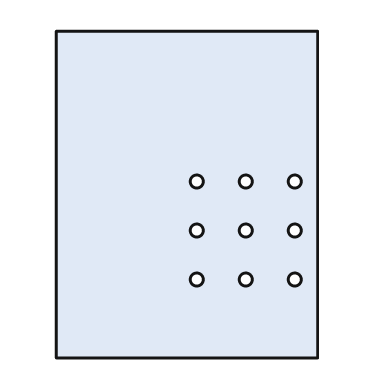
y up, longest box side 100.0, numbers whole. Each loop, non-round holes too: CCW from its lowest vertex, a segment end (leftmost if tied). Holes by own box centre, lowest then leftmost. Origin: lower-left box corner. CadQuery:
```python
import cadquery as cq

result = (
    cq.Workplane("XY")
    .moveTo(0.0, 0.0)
    .lineTo(80.0, 0.0)
    .lineTo(80.0, 100.0)
    .lineTo(0.0, 100.0)
    .close()
    .moveTo(43.0, 24.0)
    .circle(2.0)
    .moveTo(58.0, 24.0)
    .circle(2.0)
    .moveTo(73.0, 24.0)
    .circle(2.0)
    .moveTo(43.0, 39.0)
    .circle(2.0)
    .moveTo(58.0, 39.0)
    .circle(2.0)
    .moveTo(73.0, 39.0)
    .circle(2.0)
    .moveTo(43.0, 54.0)
    .circle(2.0)
    .moveTo(58.0, 54.0)
    .circle(2.0)
    .moveTo(73.0, 54.0)
    .circle(2.0)
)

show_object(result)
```